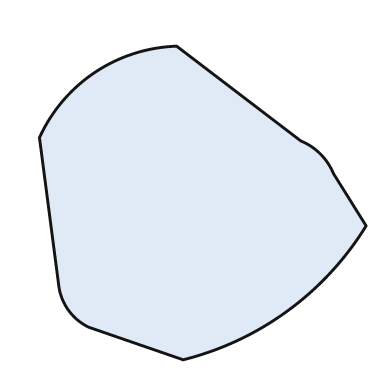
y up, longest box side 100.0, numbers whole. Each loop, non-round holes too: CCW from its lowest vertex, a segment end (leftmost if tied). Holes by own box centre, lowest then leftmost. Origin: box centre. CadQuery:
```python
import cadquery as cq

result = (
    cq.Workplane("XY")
    .moveTo(-6.0, -48.0)
    .threePointArc((26.0, -33.0), (50.0, -7.0))
    .lineTo(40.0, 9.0)
    .threePointArc((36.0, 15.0), (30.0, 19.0))
    .lineTo(-8.0, 48.0)
    .threePointArc((-33.0, 40.0), (-50.0, 20.0))
    .lineTo(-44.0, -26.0)
    .threePointArc((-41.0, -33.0), (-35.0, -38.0))
    .close()
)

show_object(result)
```